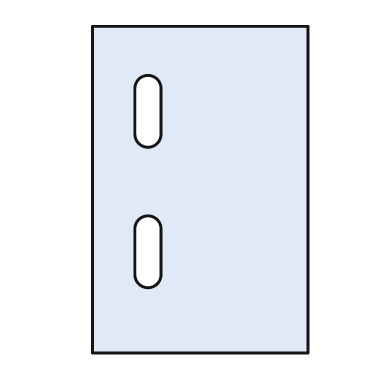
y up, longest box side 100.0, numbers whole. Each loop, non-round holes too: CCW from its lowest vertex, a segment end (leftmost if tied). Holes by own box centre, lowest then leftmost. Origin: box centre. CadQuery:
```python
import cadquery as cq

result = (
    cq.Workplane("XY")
    .moveTo(-33.0, -50.0)
    .lineTo(33.0, -50.0)
    .lineTo(33.0, 50.0)
    .lineTo(-33.0, 50.0)
    .close()
    .moveTo(-20.0, -26.0)
    .threePointArc((-16.0, -30.0), (-12.0, -26.0))
    .lineTo(-12.0, -12.0)
    .threePointArc((-16.0, -8.0), (-20.0, -12.0))
    .close()
    .moveTo(-20.0, 17.0)
    .threePointArc((-16.0, 13.0), (-12.0, 17.0))
    .lineTo(-12.0, 31.0)
    .threePointArc((-16.0, 35.0), (-20.0, 31.0))
    .close()
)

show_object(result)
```